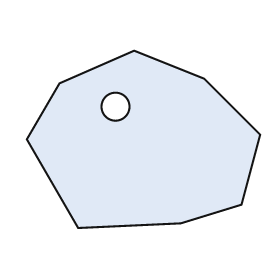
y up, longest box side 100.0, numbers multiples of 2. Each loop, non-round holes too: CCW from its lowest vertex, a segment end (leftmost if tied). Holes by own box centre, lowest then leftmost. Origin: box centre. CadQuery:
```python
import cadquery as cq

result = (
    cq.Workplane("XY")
    .moveTo(-28.0, -38.0)
    .lineTo(16.0, -36.0)
    .lineTo(42.0, -28.0)
    .lineTo(50.0, 2.0)
    .lineTo(26.0, 26.0)
    .lineTo(-4.0, 38.0)
    .lineTo(-36.0, 24.0)
    .lineTo(-50.0, 0.0)
    .close()
    .moveTo(-12.0, 14.0)
    .circle(6.0)
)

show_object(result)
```